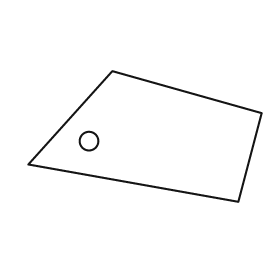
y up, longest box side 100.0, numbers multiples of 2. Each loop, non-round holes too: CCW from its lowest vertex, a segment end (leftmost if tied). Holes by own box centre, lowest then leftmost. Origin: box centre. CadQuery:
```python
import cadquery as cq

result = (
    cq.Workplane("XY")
    .moveTo(40.0, -28.0)
    .lineTo(50.0, 10.0)
    .lineTo(-14.0, 28.0)
    .lineTo(-50.0, -12.0)
    .close()
    .moveTo(-24.0, -2.0)
    .circle(4.0)
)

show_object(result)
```